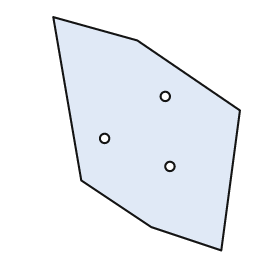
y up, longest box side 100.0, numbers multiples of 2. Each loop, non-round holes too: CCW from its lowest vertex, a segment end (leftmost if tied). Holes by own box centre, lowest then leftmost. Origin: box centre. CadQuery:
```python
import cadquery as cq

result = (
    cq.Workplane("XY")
    .moveTo(32.0, -50.0)
    .lineTo(40.0, 10.0)
    .lineTo(-4.0, 40.0)
    .lineTo(-40.0, 50.0)
    .lineTo(-28.0, -20.0)
    .lineTo(2.0, -40.0)
    .close()
    .moveTo(10.0, -14.0)
    .circle(2.0)
    .moveTo(-18.0, -2.0)
    .circle(2.0)
    .moveTo(8.0, 16.0)
    .circle(2.0)
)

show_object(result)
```